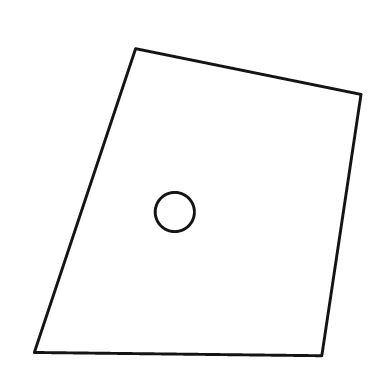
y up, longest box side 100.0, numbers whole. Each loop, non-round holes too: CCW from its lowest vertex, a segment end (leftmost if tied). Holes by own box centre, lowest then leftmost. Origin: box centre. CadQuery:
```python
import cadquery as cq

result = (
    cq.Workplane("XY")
    .moveTo(38.0, -47.0)
    .lineTo(50.0, 33.0)
    .lineTo(-19.0, 47.0)
    .lineTo(-50.0, -46.0)
    .close()
    .moveTo(-7.0, -3.0)
    .circle(6.0)
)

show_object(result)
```